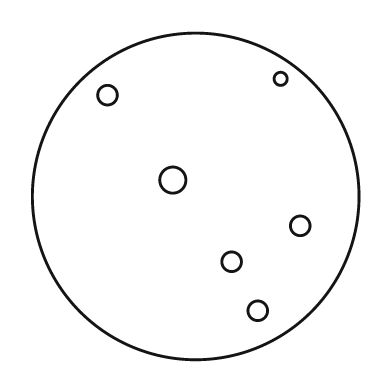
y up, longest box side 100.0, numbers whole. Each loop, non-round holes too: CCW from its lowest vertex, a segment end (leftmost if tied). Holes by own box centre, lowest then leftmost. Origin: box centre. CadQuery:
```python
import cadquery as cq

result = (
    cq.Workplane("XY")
    .moveTo(0.0, 0.0)
    .circle(50.0)
    .moveTo(19.0, -35.0)
    .circle(3.0)
    .moveTo(11.0, -20.0)
    .circle(3.0)
    .moveTo(32.0, -9.0)
    .circle(3.0)
    .moveTo(-7.0, 5.0)
    .circle(4.0)
    .moveTo(-27.0, 31.0)
    .circle(3.0)
    .moveTo(26.0, 36.0)
    .circle(2.0)
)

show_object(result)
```